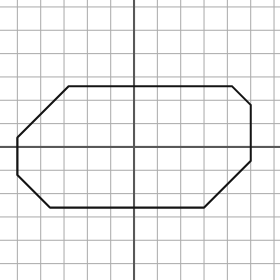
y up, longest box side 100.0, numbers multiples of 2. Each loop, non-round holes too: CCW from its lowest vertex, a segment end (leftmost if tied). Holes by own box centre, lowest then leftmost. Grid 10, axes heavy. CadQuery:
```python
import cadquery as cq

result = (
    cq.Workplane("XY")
    .moveTo(-36.0, -26.0)
    .lineTo(30.0, -26.0)
    .lineTo(50.0, -6.0)
    .lineTo(50.0, 18.0)
    .lineTo(42.0, 26.0)
    .lineTo(-28.0, 26.0)
    .lineTo(-50.0, 4.0)
    .lineTo(-50.0, -12.0)
    .close()
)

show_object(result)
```